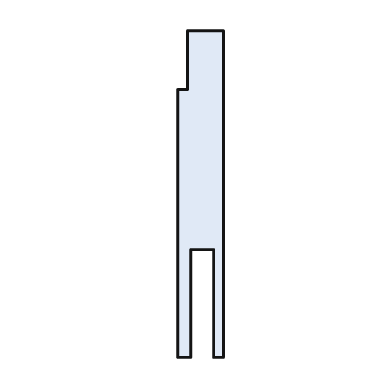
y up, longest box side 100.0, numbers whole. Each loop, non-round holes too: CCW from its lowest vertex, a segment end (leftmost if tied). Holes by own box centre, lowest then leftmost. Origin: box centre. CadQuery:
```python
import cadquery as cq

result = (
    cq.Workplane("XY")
    .moveTo(-7.0, -50.0)
    .lineTo(-3.0, -50.0)
    .lineTo(-3.0, -17.0)
    .lineTo(4.0, -17.0)
    .lineTo(4.0, -50.0)
    .lineTo(7.0, -50.0)
    .lineTo(7.0, 50.0)
    .lineTo(-4.0, 50.0)
    .lineTo(-4.0, 32.0)
    .lineTo(-7.0, 32.0)
    .close()
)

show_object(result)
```